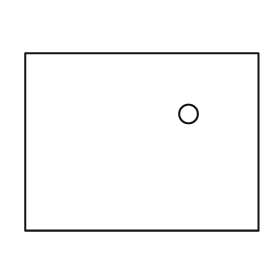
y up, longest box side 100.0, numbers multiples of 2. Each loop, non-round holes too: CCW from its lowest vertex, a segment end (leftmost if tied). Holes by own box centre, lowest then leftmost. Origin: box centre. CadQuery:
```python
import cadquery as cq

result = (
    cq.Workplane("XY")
    .moveTo(-50.0, -38.0)
    .lineTo(50.0, -38.0)
    .lineTo(50.0, 38.0)
    .lineTo(-50.0, 38.0)
    .close()
    .moveTo(20.0, 12.0)
    .circle(4.0)
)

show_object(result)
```